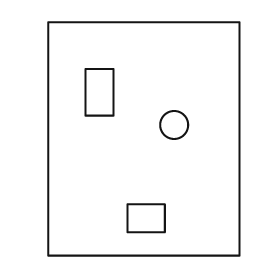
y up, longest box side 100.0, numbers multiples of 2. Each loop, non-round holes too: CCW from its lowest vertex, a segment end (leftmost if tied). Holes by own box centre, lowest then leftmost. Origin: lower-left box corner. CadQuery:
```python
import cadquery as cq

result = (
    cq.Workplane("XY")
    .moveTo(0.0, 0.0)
    .lineTo(82.0, 0.0)
    .lineTo(82.0, 100.0)
    .lineTo(0.0, 100.0)
    .close()
    .moveTo(34.0, 10.0)
    .lineTo(50.0, 10.0)
    .lineTo(50.0, 22.0)
    .lineTo(34.0, 22.0)
    .close()
    .moveTo(54.0, 56.0)
    .circle(6.0)
    .moveTo(16.0, 60.0)
    .lineTo(28.0, 60.0)
    .lineTo(28.0, 80.0)
    .lineTo(16.0, 80.0)
    .close()
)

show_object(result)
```